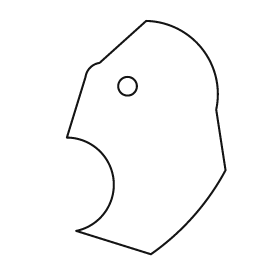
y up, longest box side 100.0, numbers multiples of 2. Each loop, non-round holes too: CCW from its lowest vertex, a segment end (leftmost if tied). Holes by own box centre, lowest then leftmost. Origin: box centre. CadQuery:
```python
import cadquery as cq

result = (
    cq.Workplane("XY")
    .moveTo(2.0, -50.0)
    .threePointArc((20.0, -34.0), (34.0, -14.0))
    .lineTo(30.0, 12.0)
    .threePointArc((24.0, 38.0), (0.0, 50.0))
    .lineTo(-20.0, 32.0)
    .threePointArc((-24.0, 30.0), (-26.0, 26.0))
    .lineTo(-34.0, 0.0)
    .threePointArc((-14.0, -18.0), (-30.0, -40.0))
    .close()
    .moveTo(-8.0, 22.0)
    .circle(4.0)
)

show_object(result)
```